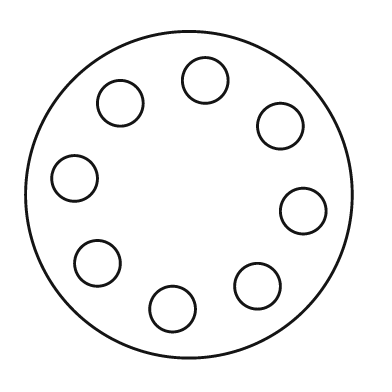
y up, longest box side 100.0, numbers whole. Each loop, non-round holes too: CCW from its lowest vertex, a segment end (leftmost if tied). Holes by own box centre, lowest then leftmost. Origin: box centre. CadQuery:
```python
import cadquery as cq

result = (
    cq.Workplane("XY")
    .moveTo(0.0, 0.0)
    .circle(50.0)
    .moveTo(-5.0, -35.0)
    .circle(7.0)
    .moveTo(21.0, -28.0)
    .circle(7.0)
    .moveTo(-28.0, -21.0)
    .circle(7.0)
    .moveTo(35.0, -5.0)
    .circle(7.0)
    .moveTo(-35.0, 5.0)
    .circle(7.0)
    .moveTo(28.0, 21.0)
    .circle(7.0)
    .moveTo(-21.0, 28.0)
    .circle(7.0)
    .moveTo(5.0, 35.0)
    .circle(7.0)
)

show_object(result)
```